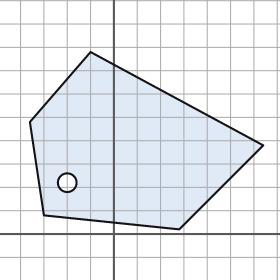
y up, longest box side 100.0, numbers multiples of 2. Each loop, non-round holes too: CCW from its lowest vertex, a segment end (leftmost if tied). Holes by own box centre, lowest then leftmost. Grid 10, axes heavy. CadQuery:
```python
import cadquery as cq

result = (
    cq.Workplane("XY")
    .moveTo(28.0, 2.0)
    .lineTo(64.0, 38.0)
    .lineTo(-10.0, 78.0)
    .lineTo(-36.0, 48.0)
    .lineTo(-30.0, 8.0)
    .close()
    .moveTo(-20.0, 22.0)
    .circle(4.0)
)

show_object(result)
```